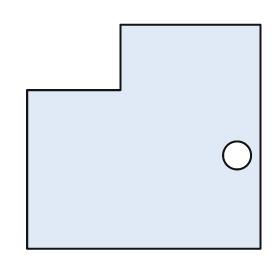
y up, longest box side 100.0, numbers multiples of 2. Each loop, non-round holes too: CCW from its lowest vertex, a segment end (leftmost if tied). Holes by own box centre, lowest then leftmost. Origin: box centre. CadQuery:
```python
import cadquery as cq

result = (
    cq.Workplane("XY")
    .moveTo(-50.0, -48.0)
    .lineTo(50.0, -48.0)
    .lineTo(50.0, 48.0)
    .lineTo(-10.0, 48.0)
    .lineTo(-10.0, 20.0)
    .lineTo(-50.0, 20.0)
    .close()
    .moveTo(40.0, -8.0)
    .circle(6.0)
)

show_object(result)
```